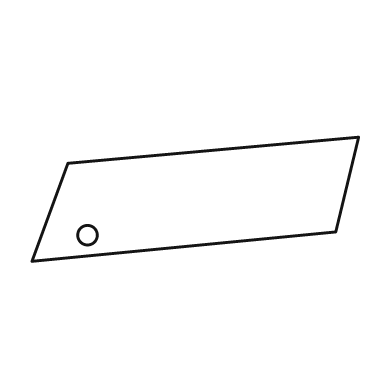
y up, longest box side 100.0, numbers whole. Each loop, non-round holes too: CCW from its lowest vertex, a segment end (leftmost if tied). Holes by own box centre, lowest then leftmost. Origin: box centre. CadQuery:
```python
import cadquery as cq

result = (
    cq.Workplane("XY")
    .moveTo(-50.0, -19.0)
    .lineTo(43.0, -10.0)
    .lineTo(50.0, 19.0)
    .lineTo(-39.0, 11.0)
    .close()
    .moveTo(-33.0, -11.0)
    .circle(3.0)
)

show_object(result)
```